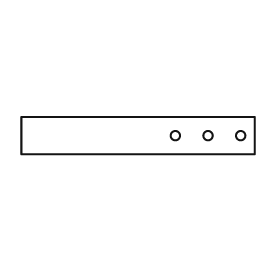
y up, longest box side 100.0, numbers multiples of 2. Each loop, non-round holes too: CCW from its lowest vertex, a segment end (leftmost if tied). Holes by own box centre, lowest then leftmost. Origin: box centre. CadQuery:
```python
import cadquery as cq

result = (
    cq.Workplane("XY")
    .moveTo(-50.0, -8.0)
    .lineTo(50.0, -8.0)
    .lineTo(50.0, 8.0)
    .lineTo(-50.0, 8.0)
    .close()
    .moveTo(16.0, 0.0)
    .circle(2.0)
    .moveTo(30.0, 0.0)
    .circle(2.0)
    .moveTo(44.0, 0.0)
    .circle(2.0)
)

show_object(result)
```